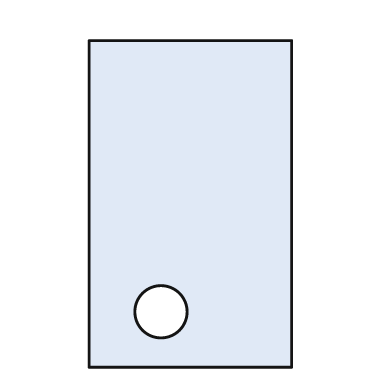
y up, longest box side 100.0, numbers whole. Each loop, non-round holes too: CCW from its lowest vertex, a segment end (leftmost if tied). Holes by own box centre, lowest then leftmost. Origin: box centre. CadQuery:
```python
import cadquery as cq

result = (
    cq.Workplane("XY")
    .moveTo(-31.0, -50.0)
    .lineTo(31.0, -50.0)
    .lineTo(31.0, 50.0)
    .lineTo(-31.0, 50.0)
    .close()
    .moveTo(-9.0, -33.0)
    .circle(8.0)
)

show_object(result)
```